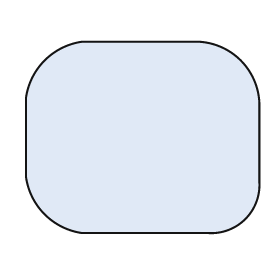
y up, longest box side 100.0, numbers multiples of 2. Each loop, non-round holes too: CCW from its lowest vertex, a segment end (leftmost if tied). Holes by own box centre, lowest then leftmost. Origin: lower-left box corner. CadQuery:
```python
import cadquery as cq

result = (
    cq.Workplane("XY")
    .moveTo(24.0, 0.0)
    .lineTo(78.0, 0.0)
    .threePointArc((94.0, 6.0), (100.0, 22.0))
    .lineTo(100.0, 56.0)
    .threePointArc((92.0, 74.0), (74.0, 82.0))
    .lineTo(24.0, 82.0)
    .threePointArc((8.0, 74.0), (0.0, 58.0))
    .lineTo(0.0, 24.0)
    .threePointArc((8.0, 8.0), (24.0, 0.0))
    .close()
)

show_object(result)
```